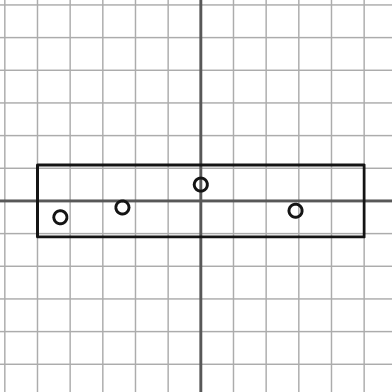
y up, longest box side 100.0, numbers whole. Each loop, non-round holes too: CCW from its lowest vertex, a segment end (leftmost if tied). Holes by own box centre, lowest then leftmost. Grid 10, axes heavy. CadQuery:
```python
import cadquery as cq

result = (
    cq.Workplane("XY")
    .moveTo(-50.0, -11.0)
    .lineTo(50.0, -11.0)
    .lineTo(50.0, 11.0)
    .lineTo(-50.0, 11.0)
    .close()
    .moveTo(-43.0, -5.0)
    .circle(2.0)
    .moveTo(29.0, -3.0)
    .circle(2.0)
    .moveTo(-24.0, -2.0)
    .circle(2.0)
    .moveTo(0.0, 5.0)
    .circle(2.0)
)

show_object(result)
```